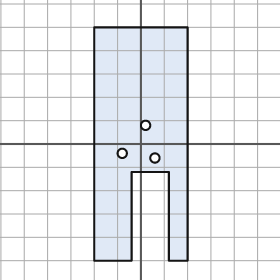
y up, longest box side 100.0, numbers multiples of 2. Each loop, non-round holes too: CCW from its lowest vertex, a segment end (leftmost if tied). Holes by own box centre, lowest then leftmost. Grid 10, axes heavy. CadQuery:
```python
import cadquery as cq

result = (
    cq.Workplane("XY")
    .moveTo(-20.0, -50.0)
    .lineTo(-4.0, -50.0)
    .lineTo(-4.0, -12.0)
    .lineTo(12.0, -12.0)
    .lineTo(12.0, -50.0)
    .lineTo(20.0, -50.0)
    .lineTo(20.0, 50.0)
    .lineTo(-20.0, 50.0)
    .close()
    .moveTo(6.0, -6.0)
    .circle(2.0)
    .moveTo(-8.0, -4.0)
    .circle(2.0)
    .moveTo(2.0, 8.0)
    .circle(2.0)
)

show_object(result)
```